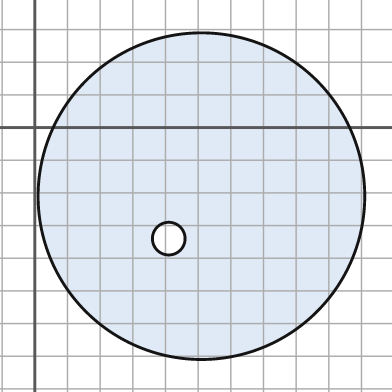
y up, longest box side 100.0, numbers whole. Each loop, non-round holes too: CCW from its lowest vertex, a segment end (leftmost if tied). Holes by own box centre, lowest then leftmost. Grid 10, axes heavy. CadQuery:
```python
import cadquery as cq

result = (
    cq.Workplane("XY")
    .moveTo(51.0, -21.0)
    .circle(50.0)
    .moveTo(41.0, -34.0)
    .circle(5.0)
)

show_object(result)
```